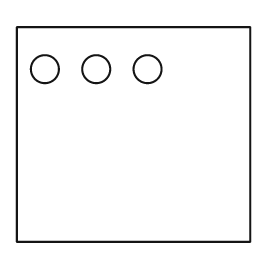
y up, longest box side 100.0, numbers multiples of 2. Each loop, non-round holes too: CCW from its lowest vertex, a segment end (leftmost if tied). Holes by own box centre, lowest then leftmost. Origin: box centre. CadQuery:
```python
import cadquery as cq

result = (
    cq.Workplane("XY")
    .moveTo(-50.0, -46.0)
    .lineTo(50.0, -46.0)
    .lineTo(50.0, 46.0)
    .lineTo(-50.0, 46.0)
    .close()
    .moveTo(-38.0, 28.0)
    .circle(6.0)
    .moveTo(-16.0, 28.0)
    .circle(6.0)
    .moveTo(6.0, 28.0)
    .circle(6.0)
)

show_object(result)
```